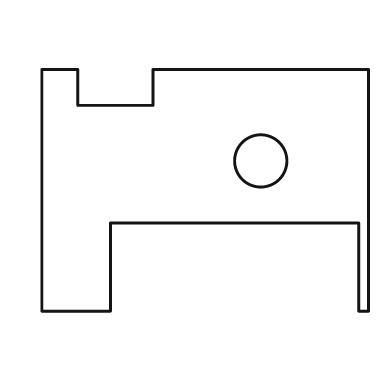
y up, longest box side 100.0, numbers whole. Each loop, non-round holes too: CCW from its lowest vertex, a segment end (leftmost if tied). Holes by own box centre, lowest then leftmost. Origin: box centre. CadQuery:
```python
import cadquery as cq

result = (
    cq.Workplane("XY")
    .moveTo(-50.0, -37.0)
    .lineTo(-29.0, -37.0)
    .lineTo(-29.0, -10.0)
    .lineTo(47.0, -10.0)
    .lineTo(47.0, -37.0)
    .lineTo(50.0, -37.0)
    .lineTo(50.0, 37.0)
    .lineTo(-16.0, 37.0)
    .lineTo(-16.0, 26.0)
    .lineTo(-39.0, 26.0)
    .lineTo(-39.0, 37.0)
    .lineTo(-50.0, 37.0)
    .close()
    .moveTo(17.0, 9.0)
    .circle(8.0)
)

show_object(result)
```